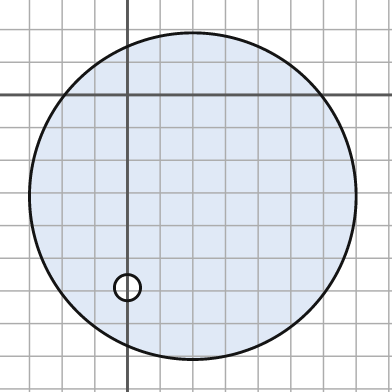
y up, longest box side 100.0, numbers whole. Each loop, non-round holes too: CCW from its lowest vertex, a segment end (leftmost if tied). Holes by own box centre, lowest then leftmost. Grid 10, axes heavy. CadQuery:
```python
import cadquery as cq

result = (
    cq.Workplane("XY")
    .moveTo(20.0, -31.0)
    .circle(50.0)
    .moveTo(0.0, -59.0)
    .circle(4.0)
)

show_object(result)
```